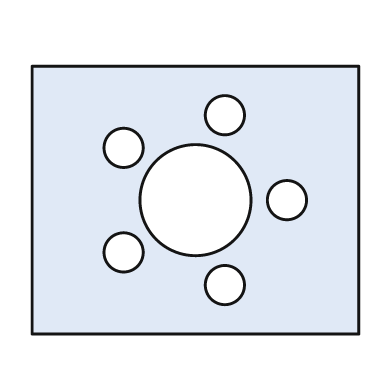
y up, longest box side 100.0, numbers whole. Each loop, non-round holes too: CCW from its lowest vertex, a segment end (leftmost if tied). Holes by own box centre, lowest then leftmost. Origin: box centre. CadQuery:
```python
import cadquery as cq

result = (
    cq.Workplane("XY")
    .moveTo(-50.0, -41.0)
    .lineTo(50.0, -41.0)
    .lineTo(50.0, 41.0)
    .lineTo(-50.0, 41.0)
    .close()
    .moveTo(9.0, -26.0)
    .circle(6.0)
    .moveTo(-22.0, -16.0)
    .circle(6.0)
    .moveTo(0.0, 0.0)
    .circle(17.0)
    .moveTo(28.0, 0.0)
    .circle(6.0)
    .moveTo(-22.0, 16.0)
    .circle(6.0)
    .moveTo(9.0, 26.0)
    .circle(6.0)
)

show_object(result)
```